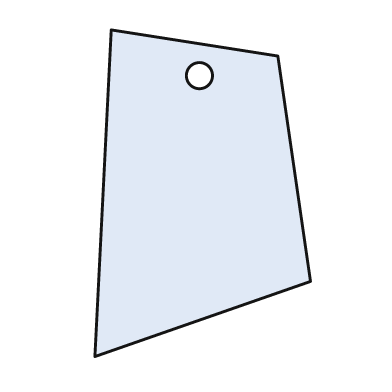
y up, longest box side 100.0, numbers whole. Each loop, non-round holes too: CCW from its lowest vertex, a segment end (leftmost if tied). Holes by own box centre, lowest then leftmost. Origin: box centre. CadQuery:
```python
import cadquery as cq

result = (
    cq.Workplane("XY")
    .moveTo(-33.0, -50.0)
    .lineTo(33.0, -27.0)
    .lineTo(23.0, 42.0)
    .lineTo(-28.0, 50.0)
    .close()
    .moveTo(-1.0, 36.0)
    .circle(4.0)
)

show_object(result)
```